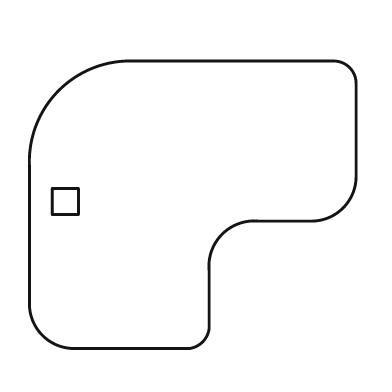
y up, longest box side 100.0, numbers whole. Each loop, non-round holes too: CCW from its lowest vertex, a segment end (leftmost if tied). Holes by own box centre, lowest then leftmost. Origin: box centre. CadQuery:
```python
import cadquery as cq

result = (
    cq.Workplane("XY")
    .moveTo(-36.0, -44.0)
    .lineTo(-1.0, -44.0)
    .threePointArc((3.0, -42.0), (5.0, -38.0))
    .lineTo(5.0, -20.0)
    .threePointArc((9.0, -9.0), (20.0, -5.0))
    .lineTo(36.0, -5.0)
    .threePointArc((46.0, -1.0), (50.0, 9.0))
    .lineTo(50.0, 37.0)
    .threePointArc((48.0, 42.0), (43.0, 44.0))
    .lineTo(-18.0, 44.0)
    .threePointArc((-41.0, 35.0), (-50.0, 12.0))
    .lineTo(-50.0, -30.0)
    .threePointArc((-46.0, -40.0), (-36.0, -44.0))
    .close()
    .moveTo(-43.0, -3.0)
    .lineTo(-35.0, -3.0)
    .lineTo(-35.0, 5.0)
    .lineTo(-43.0, 5.0)
    .close()
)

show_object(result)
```